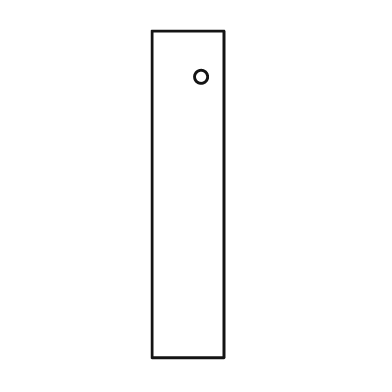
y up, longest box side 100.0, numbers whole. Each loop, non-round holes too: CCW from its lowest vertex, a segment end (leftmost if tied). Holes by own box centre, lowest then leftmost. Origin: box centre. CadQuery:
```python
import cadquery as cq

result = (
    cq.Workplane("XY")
    .moveTo(-11.0, -50.0)
    .lineTo(11.0, -50.0)
    .lineTo(11.0, 50.0)
    .lineTo(-11.0, 50.0)
    .close()
    .moveTo(4.0, 36.0)
    .circle(2.0)
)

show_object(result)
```